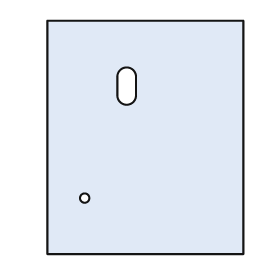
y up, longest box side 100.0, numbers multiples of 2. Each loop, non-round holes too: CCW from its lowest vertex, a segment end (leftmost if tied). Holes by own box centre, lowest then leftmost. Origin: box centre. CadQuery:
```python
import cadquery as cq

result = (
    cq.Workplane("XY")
    .moveTo(-42.0, -50.0)
    .lineTo(42.0, -50.0)
    .lineTo(42.0, 50.0)
    .lineTo(-42.0, 50.0)
    .close()
    .moveTo(-26.0, -26.0)
    .circle(2.0)
    .moveTo(-12.0, 18.0)
    .threePointArc((-8.0, 14.0), (-4.0, 18.0))
    .lineTo(-4.0, 26.0)
    .threePointArc((-8.0, 30.0), (-12.0, 26.0))
    .close()
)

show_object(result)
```